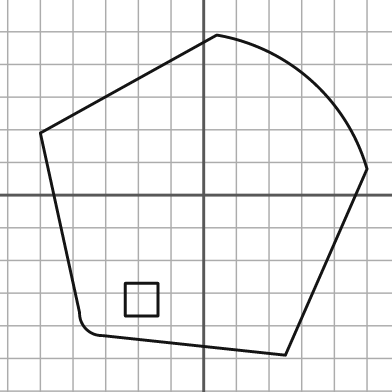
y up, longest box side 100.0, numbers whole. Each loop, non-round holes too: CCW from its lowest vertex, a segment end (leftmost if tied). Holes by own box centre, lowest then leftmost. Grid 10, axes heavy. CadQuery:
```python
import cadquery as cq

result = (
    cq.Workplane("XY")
    .moveTo(25.0, -49.0)
    .lineTo(50.0, 8.0)
    .threePointArc((33.0, 35.0), (4.0, 49.0))
    .lineTo(-50.0, 19.0)
    .lineTo(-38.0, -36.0)
    .threePointArc((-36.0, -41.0), (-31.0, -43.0))
    .close()
    .moveTo(-24.0, -37.0)
    .lineTo(-14.0, -37.0)
    .lineTo(-14.0, -27.0)
    .lineTo(-24.0, -27.0)
    .close()
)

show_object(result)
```